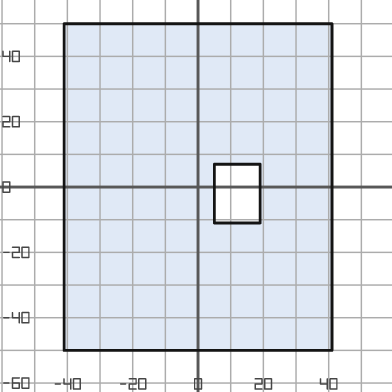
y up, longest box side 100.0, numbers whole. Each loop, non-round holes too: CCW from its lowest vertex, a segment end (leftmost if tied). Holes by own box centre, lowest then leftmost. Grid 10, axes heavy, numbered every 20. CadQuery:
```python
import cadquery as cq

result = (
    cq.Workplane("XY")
    .moveTo(-41.0, -50.0)
    .lineTo(41.0, -50.0)
    .lineTo(41.0, 50.0)
    .lineTo(-41.0, 50.0)
    .close()
    .moveTo(5.0, -11.0)
    .lineTo(19.0, -11.0)
    .lineTo(19.0, 7.0)
    .lineTo(5.0, 7.0)
    .close()
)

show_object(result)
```